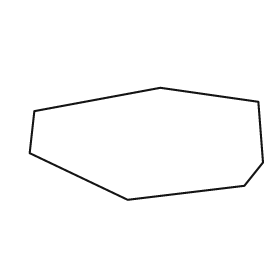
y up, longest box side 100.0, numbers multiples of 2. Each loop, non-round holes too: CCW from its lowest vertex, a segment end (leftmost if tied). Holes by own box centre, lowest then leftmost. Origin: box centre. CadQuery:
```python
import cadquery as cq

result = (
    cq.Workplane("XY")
    .moveTo(-8.0, -24.0)
    .lineTo(42.0, -18.0)
    .lineTo(50.0, -8.0)
    .lineTo(48.0, 18.0)
    .lineTo(6.0, 24.0)
    .lineTo(-48.0, 14.0)
    .lineTo(-50.0, -4.0)
    .close()
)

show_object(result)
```